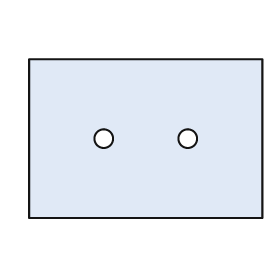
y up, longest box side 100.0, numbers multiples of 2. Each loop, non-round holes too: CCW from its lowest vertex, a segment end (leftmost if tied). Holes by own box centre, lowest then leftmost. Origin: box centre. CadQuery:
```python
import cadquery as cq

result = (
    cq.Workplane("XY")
    .moveTo(-50.0, -34.0)
    .lineTo(50.0, -34.0)
    .lineTo(50.0, 34.0)
    .lineTo(-50.0, 34.0)
    .close()
    .moveTo(-18.0, 0.0)
    .circle(4.0)
    .moveTo(18.0, 0.0)
    .circle(4.0)
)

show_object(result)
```